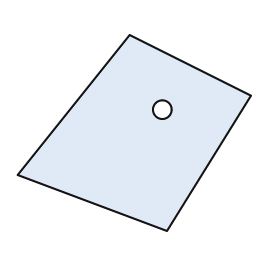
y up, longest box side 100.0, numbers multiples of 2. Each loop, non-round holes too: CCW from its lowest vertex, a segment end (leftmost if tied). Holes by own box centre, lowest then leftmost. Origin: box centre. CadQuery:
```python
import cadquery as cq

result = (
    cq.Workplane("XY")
    .moveTo(14.0, -42.0)
    .lineTo(50.0, 16.0)
    .lineTo(-2.0, 42.0)
    .lineTo(-50.0, -18.0)
    .close()
    .moveTo(12.0, 10.0)
    .circle(4.0)
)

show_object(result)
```